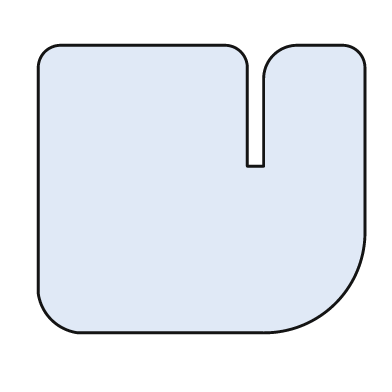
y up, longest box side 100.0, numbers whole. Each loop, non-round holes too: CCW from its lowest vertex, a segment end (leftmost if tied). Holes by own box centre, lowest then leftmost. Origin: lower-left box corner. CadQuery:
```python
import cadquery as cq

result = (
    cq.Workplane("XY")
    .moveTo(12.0, 0.0)
    .lineTo(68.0, 0.0)
    .threePointArc((91.0, 9.0), (100.0, 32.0))
    .lineTo(100.0, 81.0)
    .threePointArc((98.0, 86.0), (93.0, 88.0))
    .lineTo(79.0, 88.0)
    .threePointArc((72.0, 85.0), (69.0, 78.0))
    .lineTo(69.0, 51.0)
    .lineTo(64.0, 51.0)
    .lineTo(64.0, 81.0)
    .threePointArc((62.0, 86.0), (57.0, 88.0))
    .lineTo(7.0, 88.0)
    .threePointArc((2.0, 86.0), (0.0, 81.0))
    .lineTo(0.0, 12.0)
    .threePointArc((4.0, 4.0), (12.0, 0.0))
    .close()
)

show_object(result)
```